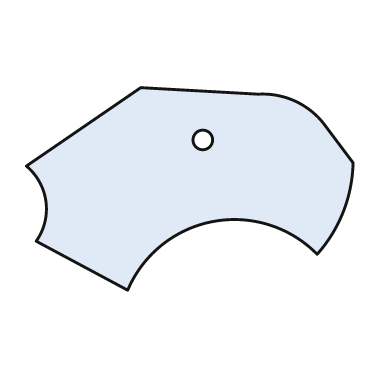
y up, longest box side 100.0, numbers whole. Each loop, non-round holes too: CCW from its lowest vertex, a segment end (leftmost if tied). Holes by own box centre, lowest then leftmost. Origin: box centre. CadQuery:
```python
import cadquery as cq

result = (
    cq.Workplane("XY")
    .moveTo(-19.0, -31.0)
    .threePointArc((7.0, -10.0), (39.0, -20.0))
    .threePointArc((47.0, -7.0), (50.0, 8.0))
    .lineTo(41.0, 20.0)
    .threePointArc((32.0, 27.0), (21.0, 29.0))
    .lineTo(-15.0, 31.0)
    .lineTo(-50.0, 7.0)
    .threePointArc((-44.0, -4.0), (-47.0, -16.0))
    .close()
    .moveTo(4.0, 15.0)
    .circle(3.0)
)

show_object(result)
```